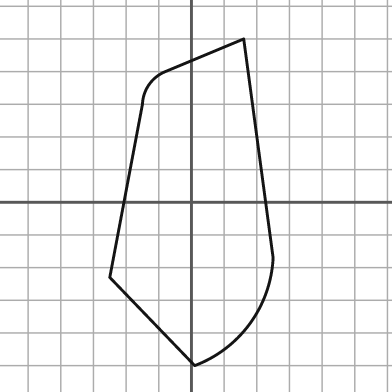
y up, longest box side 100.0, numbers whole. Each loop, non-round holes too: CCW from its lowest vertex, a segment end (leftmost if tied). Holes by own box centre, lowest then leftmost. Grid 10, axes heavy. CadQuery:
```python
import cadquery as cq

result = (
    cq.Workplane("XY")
    .moveTo(1.0, -50.0)
    .threePointArc((18.0, -37.0), (25.0, -17.0))
    .lineTo(16.0, 50.0)
    .lineTo(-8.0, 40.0)
    .threePointArc((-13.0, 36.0), (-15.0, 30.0))
    .lineTo(-25.0, -23.0)
    .close()
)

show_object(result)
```